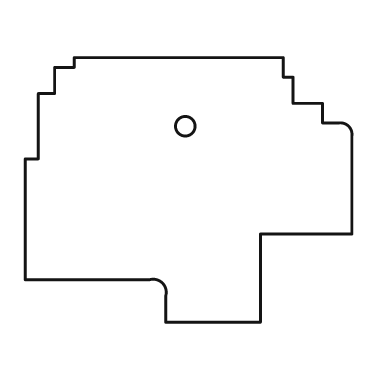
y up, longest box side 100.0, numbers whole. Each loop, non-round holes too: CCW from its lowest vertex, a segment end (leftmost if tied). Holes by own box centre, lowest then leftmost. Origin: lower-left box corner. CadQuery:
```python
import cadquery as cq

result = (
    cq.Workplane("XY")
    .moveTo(43.0, 0.0)
    .lineTo(72.0, 0.0)
    .lineTo(72.0, 27.0)
    .lineTo(100.0, 27.0)
    .lineTo(100.0, 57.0)
    .threePointArc((99.0, 60.0), (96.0, 61.0))
    .lineTo(91.0, 61.0)
    .lineTo(91.0, 67.0)
    .lineTo(82.0, 67.0)
    .lineTo(82.0, 75.0)
    .lineTo(79.0, 75.0)
    .lineTo(79.0, 81.0)
    .lineTo(15.0, 81.0)
    .lineTo(15.0, 78.0)
    .lineTo(9.0, 78.0)
    .lineTo(9.0, 70.0)
    .lineTo(4.0, 70.0)
    .lineTo(4.0, 50.0)
    .lineTo(0.0, 50.0)
    .lineTo(0.0, 13.0)
    .lineTo(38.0, 13.0)
    .threePointArc((42.0, 12.0), (43.0, 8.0))
    .close()
    .moveTo(49.0, 60.0)
    .circle(3.0)
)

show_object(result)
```